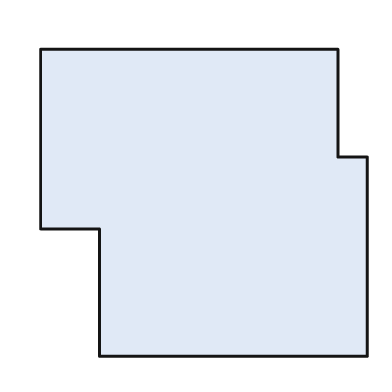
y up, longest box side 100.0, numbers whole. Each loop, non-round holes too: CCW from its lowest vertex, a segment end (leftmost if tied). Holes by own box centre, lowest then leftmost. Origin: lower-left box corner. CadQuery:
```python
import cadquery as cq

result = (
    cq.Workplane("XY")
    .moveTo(18.0, 0.0)
    .lineTo(100.0, 0.0)
    .lineTo(100.0, 61.0)
    .lineTo(91.0, 61.0)
    .lineTo(91.0, 94.0)
    .lineTo(0.0, 94.0)
    .lineTo(0.0, 39.0)
    .lineTo(18.0, 39.0)
    .close()
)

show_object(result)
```